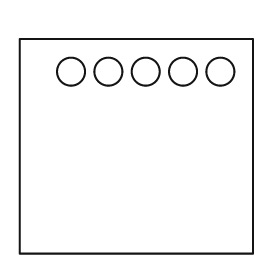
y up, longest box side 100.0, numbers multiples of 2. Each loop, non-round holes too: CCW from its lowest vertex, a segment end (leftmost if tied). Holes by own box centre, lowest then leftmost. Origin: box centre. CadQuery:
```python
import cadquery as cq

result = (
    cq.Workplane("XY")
    .moveTo(-50.0, -46.0)
    .lineTo(50.0, -46.0)
    .lineTo(50.0, 46.0)
    .lineTo(-50.0, 46.0)
    .close()
    .moveTo(-28.0, 32.0)
    .circle(6.0)
    .moveTo(-12.0, 32.0)
    .circle(6.0)
    .moveTo(4.0, 32.0)
    .circle(6.0)
    .moveTo(20.0, 32.0)
    .circle(6.0)
    .moveTo(36.0, 32.0)
    .circle(6.0)
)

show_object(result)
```